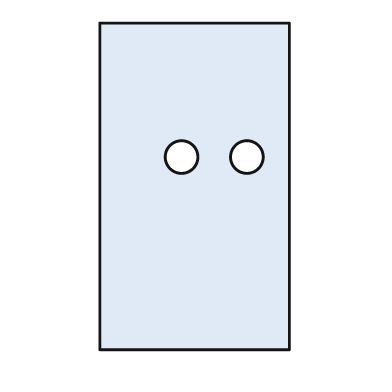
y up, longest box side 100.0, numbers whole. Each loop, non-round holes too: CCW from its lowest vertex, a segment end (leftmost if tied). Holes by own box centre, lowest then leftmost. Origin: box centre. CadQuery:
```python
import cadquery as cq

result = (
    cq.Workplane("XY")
    .moveTo(-29.0, -50.0)
    .lineTo(29.0, -50.0)
    .lineTo(29.0, 50.0)
    .lineTo(-29.0, 50.0)
    .close()
    .moveTo(-4.0, 9.0)
    .circle(5.0)
    .moveTo(16.0, 9.0)
    .circle(5.0)
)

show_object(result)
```